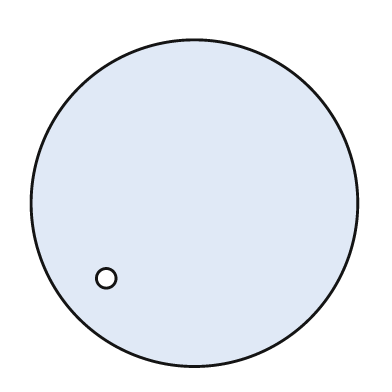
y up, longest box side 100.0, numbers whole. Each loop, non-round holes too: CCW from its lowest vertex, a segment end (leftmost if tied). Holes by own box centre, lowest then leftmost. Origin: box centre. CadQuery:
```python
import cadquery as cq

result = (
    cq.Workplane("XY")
    .moveTo(0.0, 0.0)
    .circle(50.0)
    .moveTo(-27.0, -23.0)
    .circle(3.0)
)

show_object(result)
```